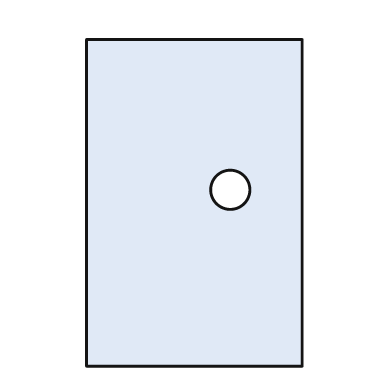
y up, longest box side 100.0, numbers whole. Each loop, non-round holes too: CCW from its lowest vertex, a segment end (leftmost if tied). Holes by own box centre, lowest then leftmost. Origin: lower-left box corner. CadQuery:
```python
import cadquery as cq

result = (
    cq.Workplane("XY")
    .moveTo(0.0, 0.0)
    .lineTo(66.0, 0.0)
    .lineTo(66.0, 100.0)
    .lineTo(0.0, 100.0)
    .close()
    .moveTo(44.0, 54.0)
    .circle(6.0)
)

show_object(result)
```